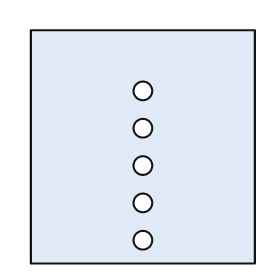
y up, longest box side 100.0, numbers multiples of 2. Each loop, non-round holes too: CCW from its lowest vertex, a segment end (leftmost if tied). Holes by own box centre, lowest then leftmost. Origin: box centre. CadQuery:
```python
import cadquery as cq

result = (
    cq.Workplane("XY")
    .moveTo(-48.0, -50.0)
    .lineTo(48.0, -50.0)
    .lineTo(48.0, 50.0)
    .lineTo(-48.0, 50.0)
    .close()
    .moveTo(0.0, -40.0)
    .circle(4.0)
    .moveTo(0.0, -24.0)
    .circle(4.0)
    .moveTo(0.0, -8.0)
    .circle(4.0)
    .moveTo(0.0, 8.0)
    .circle(4.0)
    .moveTo(0.0, 24.0)
    .circle(4.0)
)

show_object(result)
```